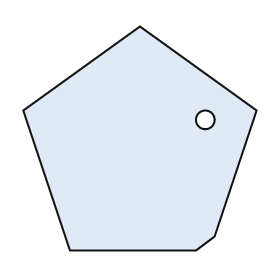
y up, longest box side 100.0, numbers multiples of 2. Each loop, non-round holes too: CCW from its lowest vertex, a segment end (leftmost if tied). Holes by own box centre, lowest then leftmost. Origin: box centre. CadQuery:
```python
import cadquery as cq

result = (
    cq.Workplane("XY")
    .moveTo(-30.0, -48.0)
    .lineTo(24.0, -48.0)
    .lineTo(32.0, -42.0)
    .lineTo(50.0, 12.0)
    .lineTo(0.0, 48.0)
    .lineTo(-50.0, 12.0)
    .close()
    .moveTo(28.0, 8.0)
    .circle(4.0)
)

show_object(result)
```